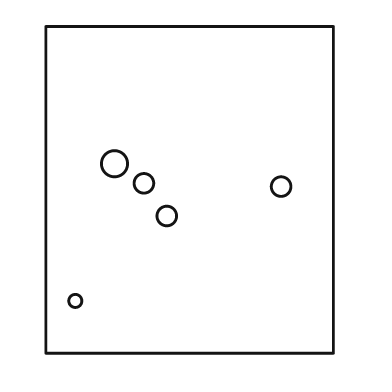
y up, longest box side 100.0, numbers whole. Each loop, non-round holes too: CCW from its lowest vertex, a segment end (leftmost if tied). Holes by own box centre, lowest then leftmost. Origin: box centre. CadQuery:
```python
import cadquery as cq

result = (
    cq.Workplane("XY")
    .moveTo(-44.0, -50.0)
    .lineTo(44.0, -50.0)
    .lineTo(44.0, 50.0)
    .lineTo(-44.0, 50.0)
    .close()
    .moveTo(-35.0, -34.0)
    .circle(2.0)
    .moveTo(-7.0, -8.0)
    .circle(3.0)
    .moveTo(28.0, 1.0)
    .circle(3.0)
    .moveTo(-14.0, 2.0)
    .circle(3.0)
    .moveTo(-23.0, 8.0)
    .circle(4.0)
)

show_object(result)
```